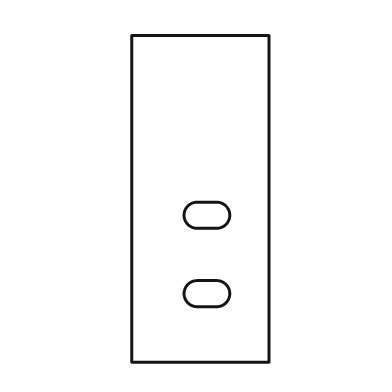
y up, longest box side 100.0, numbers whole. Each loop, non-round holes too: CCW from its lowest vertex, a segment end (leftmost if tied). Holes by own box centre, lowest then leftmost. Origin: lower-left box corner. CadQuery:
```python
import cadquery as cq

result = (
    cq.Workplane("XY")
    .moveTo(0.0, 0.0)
    .lineTo(42.0, 0.0)
    .lineTo(42.0, 100.0)
    .lineTo(0.0, 100.0)
    .close()
    .moveTo(20.0, 17.0)
    .lineTo(26.0, 17.0)
    .threePointArc((30.0, 21.0), (26.0, 25.0))
    .lineTo(20.0, 25.0)
    .threePointArc((16.0, 21.0), (20.0, 17.0))
    .close()
    .moveTo(20.0, 41.0)
    .lineTo(26.0, 41.0)
    .threePointArc((30.0, 45.0), (26.0, 49.0))
    .lineTo(20.0, 49.0)
    .threePointArc((16.0, 45.0), (20.0, 41.0))
    .close()
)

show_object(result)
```